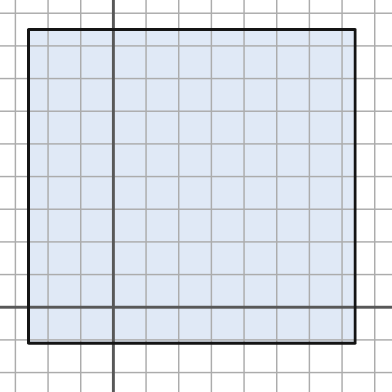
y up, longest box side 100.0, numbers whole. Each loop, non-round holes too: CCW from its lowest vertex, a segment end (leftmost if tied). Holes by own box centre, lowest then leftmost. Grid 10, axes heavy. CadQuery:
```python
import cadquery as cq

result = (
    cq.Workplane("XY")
    .moveTo(-26.0, -11.0)
    .lineTo(74.0, -11.0)
    .lineTo(74.0, 85.0)
    .lineTo(-26.0, 85.0)
    .close()
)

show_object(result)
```